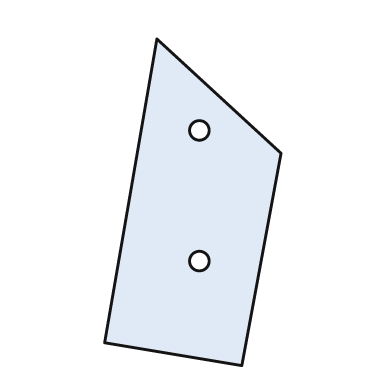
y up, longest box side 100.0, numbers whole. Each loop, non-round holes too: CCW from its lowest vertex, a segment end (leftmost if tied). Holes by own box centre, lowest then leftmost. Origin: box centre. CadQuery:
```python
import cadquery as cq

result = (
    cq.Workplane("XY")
    .moveTo(15.0, -50.0)
    .lineTo(27.0, 15.0)
    .lineTo(-11.0, 50.0)
    .lineTo(-27.0, -43.0)
    .close()
    .moveTo(2.0, -18.0)
    .circle(3.0)
    .moveTo(2.0, 22.0)
    .circle(3.0)
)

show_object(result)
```